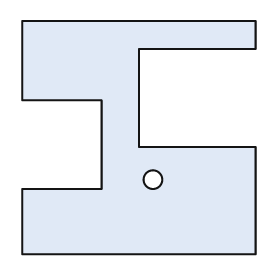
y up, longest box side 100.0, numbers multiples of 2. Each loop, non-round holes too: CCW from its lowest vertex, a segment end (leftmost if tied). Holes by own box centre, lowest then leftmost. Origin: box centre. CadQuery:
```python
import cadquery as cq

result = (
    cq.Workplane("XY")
    .moveTo(-50.0, -50.0)
    .lineTo(50.0, -50.0)
    .lineTo(50.0, -4.0)
    .lineTo(0.0, -4.0)
    .lineTo(0.0, 38.0)
    .lineTo(50.0, 38.0)
    .lineTo(50.0, 50.0)
    .lineTo(-50.0, 50.0)
    .lineTo(-50.0, 16.0)
    .lineTo(-16.0, 16.0)
    .lineTo(-16.0, -22.0)
    .lineTo(-50.0, -22.0)
    .close()
    .moveTo(6.0, -18.0)
    .circle(4.0)
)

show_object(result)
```